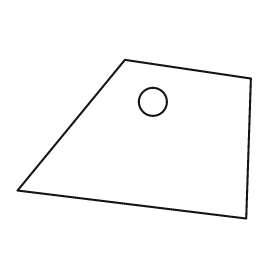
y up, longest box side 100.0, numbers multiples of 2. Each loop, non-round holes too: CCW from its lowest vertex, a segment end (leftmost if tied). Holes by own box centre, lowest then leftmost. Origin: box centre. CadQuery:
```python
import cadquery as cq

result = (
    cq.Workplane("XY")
    .moveTo(48.0, -34.0)
    .lineTo(50.0, 26.0)
    .lineTo(-4.0, 34.0)
    .lineTo(-50.0, -22.0)
    .close()
    .moveTo(8.0, 16.0)
    .circle(6.0)
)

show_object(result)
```